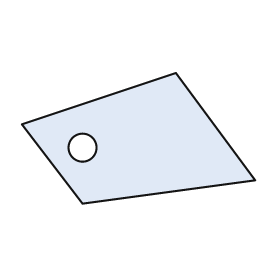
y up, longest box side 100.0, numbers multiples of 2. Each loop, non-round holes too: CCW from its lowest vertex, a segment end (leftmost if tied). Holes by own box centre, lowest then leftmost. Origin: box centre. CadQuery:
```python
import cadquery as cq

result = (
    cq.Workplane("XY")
    .moveTo(-24.0, -28.0)
    .lineTo(50.0, -18.0)
    .lineTo(16.0, 28.0)
    .lineTo(-50.0, 6.0)
    .close()
    .moveTo(-24.0, -4.0)
    .circle(6.0)
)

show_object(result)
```